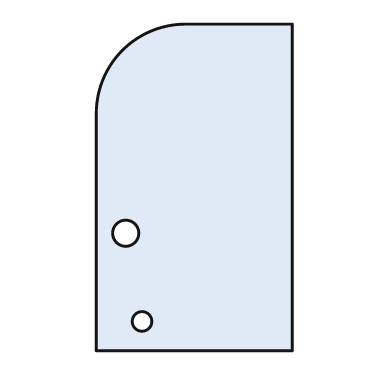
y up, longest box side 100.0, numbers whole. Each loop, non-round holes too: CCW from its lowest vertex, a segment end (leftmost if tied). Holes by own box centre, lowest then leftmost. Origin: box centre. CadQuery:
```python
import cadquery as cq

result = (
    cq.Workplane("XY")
    .moveTo(-30.0, -50.0)
    .lineTo(30.0, -50.0)
    .lineTo(30.0, 50.0)
    .lineTo(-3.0, 50.0)
    .threePointArc((-22.0, 42.0), (-30.0, 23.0))
    .close()
    .moveTo(-16.0, -41.0)
    .circle(3.0)
    .moveTo(-21.0, -14.0)
    .circle(4.0)
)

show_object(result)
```